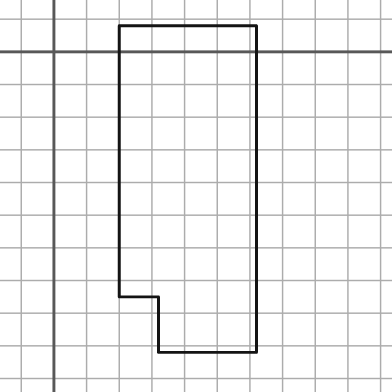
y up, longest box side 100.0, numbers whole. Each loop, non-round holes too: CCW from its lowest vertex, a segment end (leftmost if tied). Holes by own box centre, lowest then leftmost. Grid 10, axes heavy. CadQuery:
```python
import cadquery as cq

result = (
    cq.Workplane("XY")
    .moveTo(32.0, -92.0)
    .lineTo(62.0, -92.0)
    .lineTo(62.0, 8.0)
    .lineTo(20.0, 8.0)
    .lineTo(20.0, -75.0)
    .lineTo(32.0, -75.0)
    .close()
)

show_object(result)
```